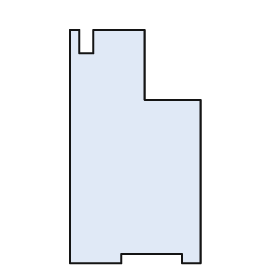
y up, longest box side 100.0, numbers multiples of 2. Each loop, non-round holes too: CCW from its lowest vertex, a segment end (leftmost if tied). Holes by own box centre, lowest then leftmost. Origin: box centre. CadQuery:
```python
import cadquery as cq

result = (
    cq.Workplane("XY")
    .moveTo(-28.0, -50.0)
    .lineTo(-6.0, -50.0)
    .lineTo(-6.0, -46.0)
    .lineTo(20.0, -46.0)
    .lineTo(20.0, -50.0)
    .lineTo(28.0, -50.0)
    .lineTo(28.0, 20.0)
    .lineTo(4.0, 20.0)
    .lineTo(4.0, 50.0)
    .lineTo(-18.0, 50.0)
    .lineTo(-18.0, 40.0)
    .lineTo(-24.0, 40.0)
    .lineTo(-24.0, 50.0)
    .lineTo(-28.0, 50.0)
    .close()
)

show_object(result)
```